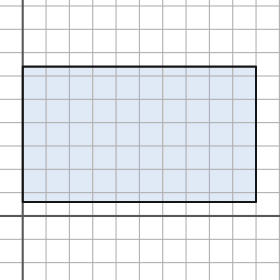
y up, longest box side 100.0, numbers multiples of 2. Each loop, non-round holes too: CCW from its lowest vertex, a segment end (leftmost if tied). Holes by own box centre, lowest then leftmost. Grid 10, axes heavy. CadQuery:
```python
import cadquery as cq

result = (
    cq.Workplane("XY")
    .moveTo(0.0, 6.0)
    .lineTo(100.0, 6.0)
    .lineTo(100.0, 64.0)
    .lineTo(0.0, 64.0)
    .close()
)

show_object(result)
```